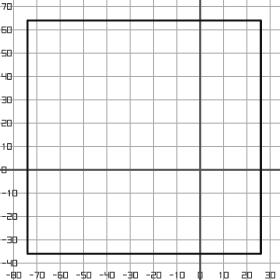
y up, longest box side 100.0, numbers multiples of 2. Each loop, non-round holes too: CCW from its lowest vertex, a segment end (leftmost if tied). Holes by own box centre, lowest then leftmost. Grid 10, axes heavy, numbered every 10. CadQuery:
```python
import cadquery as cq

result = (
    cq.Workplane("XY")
    .moveTo(-74.0, -36.0)
    .lineTo(26.0, -36.0)
    .lineTo(26.0, 64.0)
    .lineTo(-74.0, 64.0)
    .close()
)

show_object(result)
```